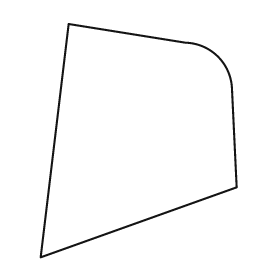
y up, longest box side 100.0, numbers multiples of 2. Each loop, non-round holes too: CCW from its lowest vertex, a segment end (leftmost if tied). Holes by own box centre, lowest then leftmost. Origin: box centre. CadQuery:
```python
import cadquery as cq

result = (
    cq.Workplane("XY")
    .moveTo(-42.0, -50.0)
    .lineTo(42.0, -20.0)
    .lineTo(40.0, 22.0)
    .threePointArc((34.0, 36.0), (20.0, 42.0))
    .lineTo(-30.0, 50.0)
    .close()
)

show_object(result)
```